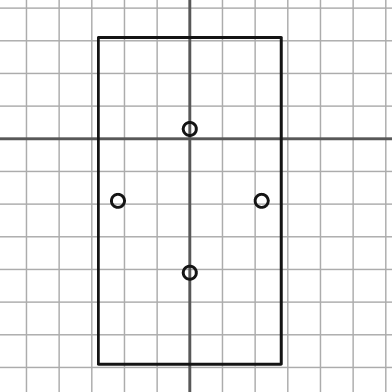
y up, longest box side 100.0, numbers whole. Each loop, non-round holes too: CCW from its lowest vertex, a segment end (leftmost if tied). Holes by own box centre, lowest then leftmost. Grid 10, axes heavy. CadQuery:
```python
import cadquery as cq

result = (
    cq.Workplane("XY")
    .moveTo(-28.0, -69.0)
    .lineTo(28.0, -69.0)
    .lineTo(28.0, 31.0)
    .lineTo(-28.0, 31.0)
    .close()
    .moveTo(0.0, -41.0)
    .circle(2.0)
    .moveTo(-22.0, -19.0)
    .circle(2.0)
    .moveTo(22.0, -19.0)
    .circle(2.0)
    .moveTo(0.0, 3.0)
    .circle(2.0)
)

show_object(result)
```